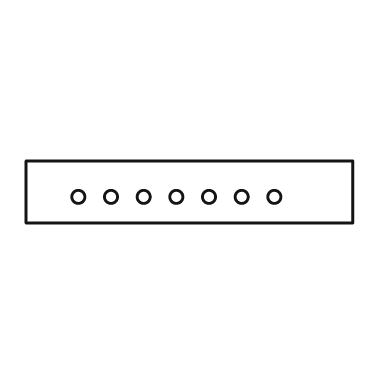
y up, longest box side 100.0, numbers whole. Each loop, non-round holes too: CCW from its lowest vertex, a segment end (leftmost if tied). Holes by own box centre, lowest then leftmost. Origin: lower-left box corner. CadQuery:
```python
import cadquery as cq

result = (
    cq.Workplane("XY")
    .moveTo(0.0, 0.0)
    .lineTo(100.0, 0.0)
    .lineTo(100.0, 19.0)
    .lineTo(0.0, 19.0)
    .close()
    .moveTo(16.0, 8.0)
    .circle(2.0)
    .moveTo(26.0, 8.0)
    .circle(2.0)
    .moveTo(36.0, 8.0)
    .circle(2.0)
    .moveTo(46.0, 8.0)
    .circle(2.0)
    .moveTo(56.0, 8.0)
    .circle(2.0)
    .moveTo(66.0, 8.0)
    .circle(2.0)
    .moveTo(76.0, 8.0)
    .circle(2.0)
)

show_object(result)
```